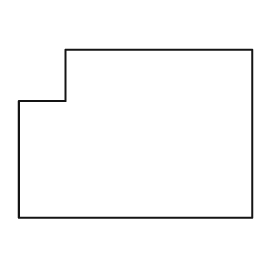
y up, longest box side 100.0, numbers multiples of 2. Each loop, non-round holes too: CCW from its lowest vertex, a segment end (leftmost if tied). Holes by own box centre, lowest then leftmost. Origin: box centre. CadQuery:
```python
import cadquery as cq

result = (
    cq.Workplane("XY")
    .moveTo(-50.0, -36.0)
    .lineTo(50.0, -36.0)
    .lineTo(50.0, 36.0)
    .lineTo(-30.0, 36.0)
    .lineTo(-30.0, 14.0)
    .lineTo(-50.0, 14.0)
    .close()
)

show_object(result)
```